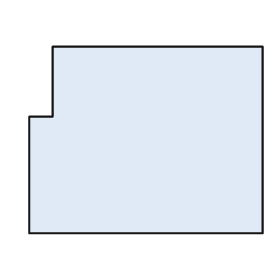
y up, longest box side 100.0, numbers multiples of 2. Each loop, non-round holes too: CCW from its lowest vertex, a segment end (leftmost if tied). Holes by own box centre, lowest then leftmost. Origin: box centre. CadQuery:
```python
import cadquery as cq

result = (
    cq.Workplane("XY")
    .moveTo(-50.0, -40.0)
    .lineTo(50.0, -40.0)
    .lineTo(50.0, 40.0)
    .lineTo(-40.0, 40.0)
    .lineTo(-40.0, 10.0)
    .lineTo(-50.0, 10.0)
    .close()
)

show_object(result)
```